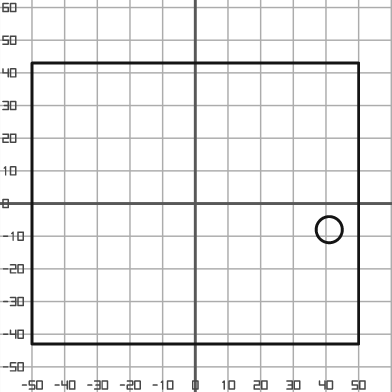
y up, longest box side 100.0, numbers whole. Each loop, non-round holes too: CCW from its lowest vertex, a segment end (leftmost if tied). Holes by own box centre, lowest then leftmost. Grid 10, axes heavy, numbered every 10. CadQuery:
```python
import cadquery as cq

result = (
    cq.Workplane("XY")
    .moveTo(-50.0, -43.0)
    .lineTo(50.0, -43.0)
    .lineTo(50.0, 43.0)
    .lineTo(-50.0, 43.0)
    .close()
    .moveTo(41.0, -8.0)
    .circle(4.0)
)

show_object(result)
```